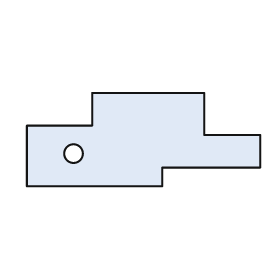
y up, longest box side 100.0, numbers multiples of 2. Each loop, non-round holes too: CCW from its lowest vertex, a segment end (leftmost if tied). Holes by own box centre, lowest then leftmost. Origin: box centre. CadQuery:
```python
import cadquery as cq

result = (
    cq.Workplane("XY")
    .moveTo(-50.0, -20.0)
    .lineTo(8.0, -20.0)
    .lineTo(8.0, -12.0)
    .lineTo(50.0, -12.0)
    .lineTo(50.0, 2.0)
    .lineTo(26.0, 2.0)
    .lineTo(26.0, 20.0)
    .lineTo(-22.0, 20.0)
    .lineTo(-22.0, 6.0)
    .lineTo(-50.0, 6.0)
    .close()
    .moveTo(-30.0, -6.0)
    .circle(4.0)
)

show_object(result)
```